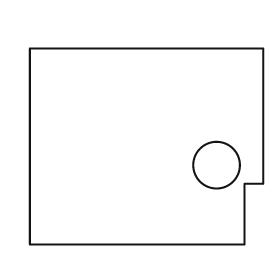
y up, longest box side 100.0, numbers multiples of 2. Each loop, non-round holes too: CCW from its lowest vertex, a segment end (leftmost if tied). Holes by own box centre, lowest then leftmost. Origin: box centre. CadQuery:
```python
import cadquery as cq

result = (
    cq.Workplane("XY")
    .moveTo(-50.0, -42.0)
    .lineTo(42.0, -42.0)
    .lineTo(42.0, -16.0)
    .lineTo(50.0, -16.0)
    .lineTo(50.0, 42.0)
    .lineTo(-50.0, 42.0)
    .close()
    .moveTo(30.0, -8.0)
    .circle(10.0)
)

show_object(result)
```